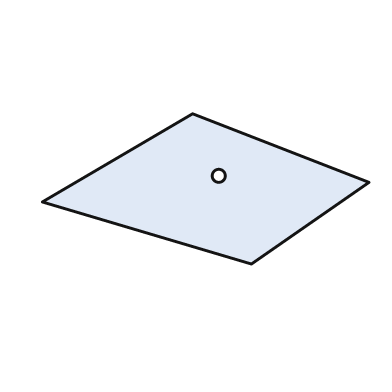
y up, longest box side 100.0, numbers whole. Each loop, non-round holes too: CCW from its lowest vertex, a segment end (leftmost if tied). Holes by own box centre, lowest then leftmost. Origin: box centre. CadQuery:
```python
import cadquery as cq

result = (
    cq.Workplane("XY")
    .moveTo(14.0, -23.0)
    .lineTo(50.0, 2.0)
    .lineTo(-4.0, 23.0)
    .lineTo(-50.0, -4.0)
    .close()
    .moveTo(4.0, 4.0)
    .circle(2.0)
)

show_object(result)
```